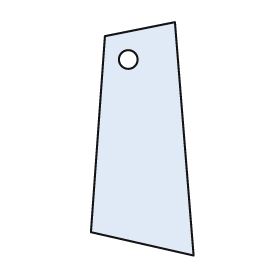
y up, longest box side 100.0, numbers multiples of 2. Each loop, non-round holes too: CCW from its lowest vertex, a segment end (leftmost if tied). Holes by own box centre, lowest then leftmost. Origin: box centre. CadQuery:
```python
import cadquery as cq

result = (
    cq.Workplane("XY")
    .moveTo(22.0, -50.0)
    .lineTo(14.0, 50.0)
    .lineTo(-16.0, 44.0)
    .lineTo(-22.0, -40.0)
    .close()
    .moveTo(-6.0, 34.0)
    .circle(4.0)
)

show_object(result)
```